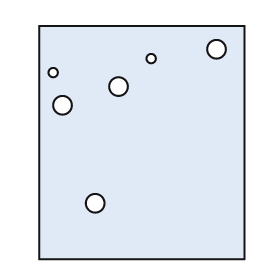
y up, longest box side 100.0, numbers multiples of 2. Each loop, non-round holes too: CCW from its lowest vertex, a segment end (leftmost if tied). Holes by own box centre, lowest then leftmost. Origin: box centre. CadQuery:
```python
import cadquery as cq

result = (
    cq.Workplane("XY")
    .moveTo(-44.0, -50.0)
    .lineTo(44.0, -50.0)
    .lineTo(44.0, 50.0)
    .lineTo(-44.0, 50.0)
    .close()
    .moveTo(-20.0, -26.0)
    .circle(4.0)
    .moveTo(-34.0, 16.0)
    .circle(4.0)
    .moveTo(-10.0, 24.0)
    .circle(4.0)
    .moveTo(-38.0, 30.0)
    .circle(2.0)
    .moveTo(4.0, 36.0)
    .circle(2.0)
    .moveTo(32.0, 40.0)
    .circle(4.0)
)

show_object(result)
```